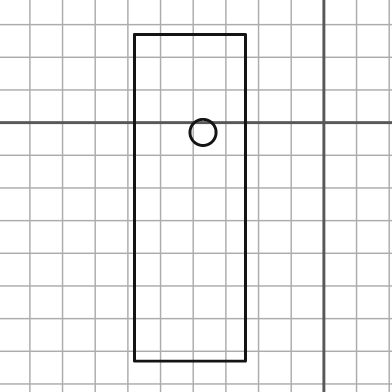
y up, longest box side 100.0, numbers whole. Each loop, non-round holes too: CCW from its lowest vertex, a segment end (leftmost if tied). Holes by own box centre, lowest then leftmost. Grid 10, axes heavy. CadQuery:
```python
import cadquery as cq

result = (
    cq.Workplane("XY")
    .moveTo(-58.0, -73.0)
    .lineTo(-24.0, -73.0)
    .lineTo(-24.0, 27.0)
    .lineTo(-58.0, 27.0)
    .close()
    .moveTo(-37.0, -3.0)
    .circle(4.0)
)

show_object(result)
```